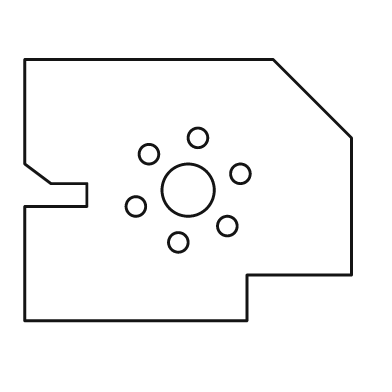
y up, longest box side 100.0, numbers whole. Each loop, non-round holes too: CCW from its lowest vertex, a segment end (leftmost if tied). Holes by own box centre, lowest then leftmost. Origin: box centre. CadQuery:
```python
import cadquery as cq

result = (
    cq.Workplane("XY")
    .moveTo(-50.0, -40.0)
    .lineTo(18.0, -40.0)
    .lineTo(18.0, -26.0)
    .lineTo(50.0, -26.0)
    .lineTo(50.0, 16.0)
    .lineTo(26.0, 40.0)
    .lineTo(-50.0, 40.0)
    .lineTo(-50.0, 8.0)
    .lineTo(-42.0, 2.0)
    .lineTo(-31.0, 2.0)
    .lineTo(-31.0, -5.0)
    .lineTo(-50.0, -5.0)
    .close()
    .moveTo(-3.0, -16.0)
    .circle(3.0)
    .moveTo(12.0, -11.0)
    .circle(3.0)
    .moveTo(-16.0, -5.0)
    .circle(3.0)
    .moveTo(0.0, 0.0)
    .circle(8.0)
    .moveTo(16.0, 5.0)
    .circle(3.0)
    .moveTo(-12.0, 11.0)
    .circle(3.0)
    .moveTo(3.0, 16.0)
    .circle(3.0)
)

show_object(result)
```